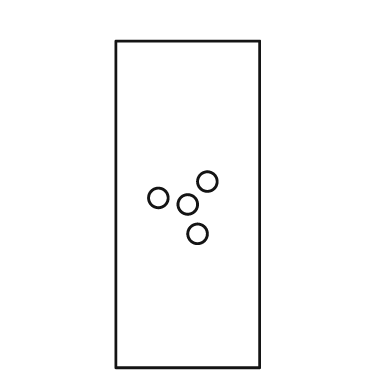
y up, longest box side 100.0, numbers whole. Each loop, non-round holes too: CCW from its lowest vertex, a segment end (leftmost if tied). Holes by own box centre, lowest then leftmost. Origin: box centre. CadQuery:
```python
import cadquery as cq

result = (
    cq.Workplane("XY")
    .moveTo(-22.0, -50.0)
    .lineTo(22.0, -50.0)
    .lineTo(22.0, 50.0)
    .lineTo(-22.0, 50.0)
    .close()
    .moveTo(3.0, -9.0)
    .circle(3.0)
    .moveTo(0.0, 0.0)
    .circle(3.0)
    .moveTo(-9.0, 2.0)
    .circle(3.0)
    .moveTo(6.0, 7.0)
    .circle(3.0)
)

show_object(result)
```